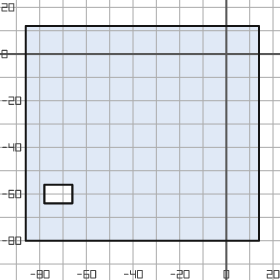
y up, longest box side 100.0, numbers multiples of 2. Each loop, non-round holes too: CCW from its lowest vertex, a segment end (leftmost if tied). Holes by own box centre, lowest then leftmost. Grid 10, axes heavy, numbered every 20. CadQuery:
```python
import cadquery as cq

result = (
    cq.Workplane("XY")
    .moveTo(-86.0, -80.0)
    .lineTo(14.0, -80.0)
    .lineTo(14.0, 12.0)
    .lineTo(-86.0, 12.0)
    .close()
    .moveTo(-78.0, -64.0)
    .lineTo(-66.0, -64.0)
    .lineTo(-66.0, -56.0)
    .lineTo(-78.0, -56.0)
    .close()
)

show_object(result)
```